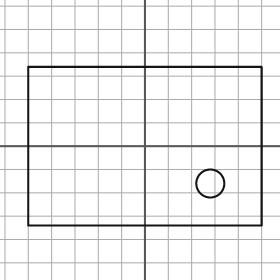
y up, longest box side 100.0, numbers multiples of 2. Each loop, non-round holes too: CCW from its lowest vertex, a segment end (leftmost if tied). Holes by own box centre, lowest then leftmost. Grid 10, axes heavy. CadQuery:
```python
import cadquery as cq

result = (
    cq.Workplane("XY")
    .moveTo(-50.0, -34.0)
    .lineTo(50.0, -34.0)
    .lineTo(50.0, 34.0)
    .lineTo(-50.0, 34.0)
    .close()
    .moveTo(28.0, -16.0)
    .circle(6.0)
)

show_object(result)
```